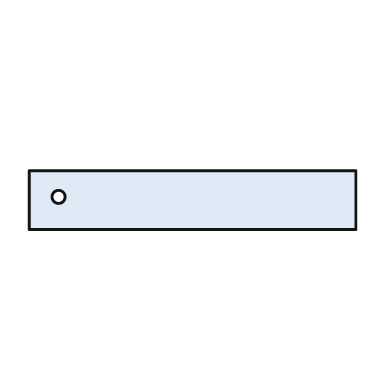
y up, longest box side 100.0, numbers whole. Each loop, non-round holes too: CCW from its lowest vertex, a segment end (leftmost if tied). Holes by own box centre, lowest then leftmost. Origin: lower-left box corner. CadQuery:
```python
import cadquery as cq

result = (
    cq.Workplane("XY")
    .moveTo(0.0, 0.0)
    .lineTo(100.0, 0.0)
    .lineTo(100.0, 18.0)
    .lineTo(0.0, 18.0)
    .close()
    .moveTo(9.0, 10.0)
    .circle(2.0)
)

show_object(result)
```